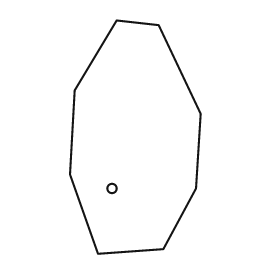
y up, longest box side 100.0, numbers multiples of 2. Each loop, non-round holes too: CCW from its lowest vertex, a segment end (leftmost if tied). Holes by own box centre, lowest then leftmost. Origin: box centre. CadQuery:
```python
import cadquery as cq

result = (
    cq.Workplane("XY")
    .moveTo(-16.0, -50.0)
    .lineTo(12.0, -48.0)
    .lineTo(26.0, -22.0)
    .lineTo(28.0, 10.0)
    .lineTo(10.0, 48.0)
    .lineTo(-8.0, 50.0)
    .lineTo(-26.0, 20.0)
    .lineTo(-28.0, -16.0)
    .close()
    .moveTo(-10.0, -22.0)
    .circle(2.0)
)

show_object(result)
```